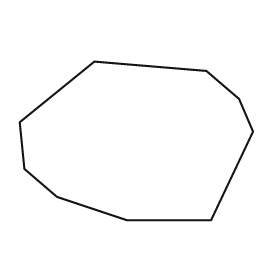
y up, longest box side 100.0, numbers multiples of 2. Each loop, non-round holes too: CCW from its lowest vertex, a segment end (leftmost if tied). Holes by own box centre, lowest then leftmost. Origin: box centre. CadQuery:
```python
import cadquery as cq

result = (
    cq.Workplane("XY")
    .moveTo(-4.0, -34.0)
    .lineTo(32.0, -34.0)
    .lineTo(50.0, 4.0)
    .lineTo(44.0, 18.0)
    .lineTo(30.0, 30.0)
    .lineTo(-18.0, 34.0)
    .lineTo(-50.0, 8.0)
    .lineTo(-48.0, -12.0)
    .lineTo(-34.0, -24.0)
    .close()
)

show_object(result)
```